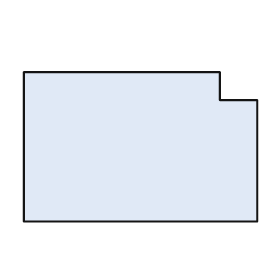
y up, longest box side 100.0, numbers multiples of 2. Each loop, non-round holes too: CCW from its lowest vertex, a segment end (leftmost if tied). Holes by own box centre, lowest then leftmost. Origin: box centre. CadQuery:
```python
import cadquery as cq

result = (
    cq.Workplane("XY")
    .moveTo(-50.0, -32.0)
    .lineTo(50.0, -32.0)
    .lineTo(50.0, 20.0)
    .lineTo(34.0, 20.0)
    .lineTo(34.0, 32.0)
    .lineTo(-50.0, 32.0)
    .close()
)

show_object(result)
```